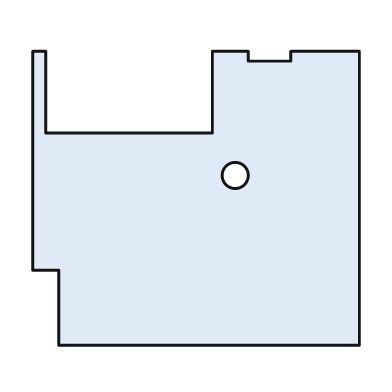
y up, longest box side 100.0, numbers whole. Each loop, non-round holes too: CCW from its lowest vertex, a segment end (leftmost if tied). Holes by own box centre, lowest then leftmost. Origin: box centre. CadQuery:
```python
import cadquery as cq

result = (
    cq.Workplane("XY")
    .moveTo(-42.0, -45.0)
    .lineTo(50.0, -45.0)
    .lineTo(50.0, 45.0)
    .lineTo(29.0, 45.0)
    .lineTo(29.0, 42.0)
    .lineTo(16.0, 42.0)
    .lineTo(16.0, 45.0)
    .lineTo(5.0, 45.0)
    .lineTo(5.0, 20.0)
    .lineTo(-46.0, 20.0)
    .lineTo(-46.0, 45.0)
    .lineTo(-50.0, 45.0)
    .lineTo(-50.0, -22.0)
    .lineTo(-42.0, -22.0)
    .close()
    .moveTo(12.0, 7.0)
    .circle(4.0)
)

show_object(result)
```